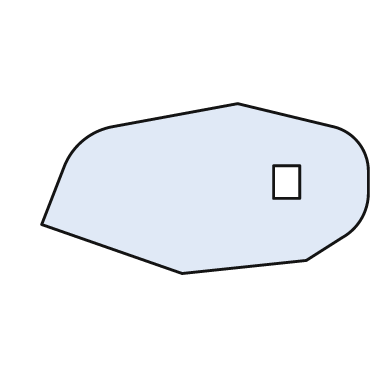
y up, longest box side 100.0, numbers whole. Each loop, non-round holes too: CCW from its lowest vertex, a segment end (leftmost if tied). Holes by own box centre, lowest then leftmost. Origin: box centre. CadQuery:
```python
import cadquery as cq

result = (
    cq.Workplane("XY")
    .moveTo(-7.0, -26.0)
    .lineTo(31.0, -22.0)
    .lineTo(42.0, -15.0)
    .threePointArc((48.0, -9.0), (50.0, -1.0))
    .lineTo(50.0, 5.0)
    .threePointArc((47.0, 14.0), (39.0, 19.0))
    .lineTo(10.0, 26.0)
    .lineTo(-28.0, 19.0)
    .threePointArc((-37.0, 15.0), (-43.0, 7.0))
    .lineTo(-50.0, -11.0)
    .close()
    .moveTo(21.0, -3.0)
    .lineTo(29.0, -3.0)
    .lineTo(29.0, 7.0)
    .lineTo(21.0, 7.0)
    .close()
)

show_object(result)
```